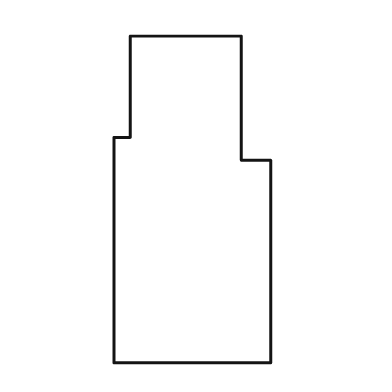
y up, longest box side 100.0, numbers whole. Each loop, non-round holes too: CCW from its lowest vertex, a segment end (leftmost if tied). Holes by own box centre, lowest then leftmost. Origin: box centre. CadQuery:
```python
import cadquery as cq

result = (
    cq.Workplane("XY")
    .moveTo(-24.0, -50.0)
    .lineTo(24.0, -50.0)
    .lineTo(24.0, 12.0)
    .lineTo(15.0, 12.0)
    .lineTo(15.0, 50.0)
    .lineTo(-19.0, 50.0)
    .lineTo(-19.0, 19.0)
    .lineTo(-24.0, 19.0)
    .close()
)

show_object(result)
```